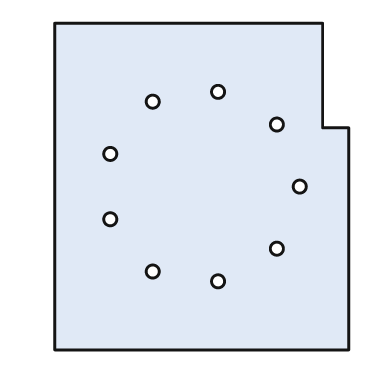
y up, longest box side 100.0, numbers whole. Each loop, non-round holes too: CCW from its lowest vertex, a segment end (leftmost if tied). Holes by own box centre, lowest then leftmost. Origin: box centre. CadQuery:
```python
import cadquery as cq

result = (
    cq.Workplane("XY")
    .moveTo(-45.0, -50.0)
    .lineTo(45.0, -50.0)
    .lineTo(45.0, 18.0)
    .lineTo(37.0, 18.0)
    .lineTo(37.0, 50.0)
    .lineTo(-45.0, 50.0)
    .close()
    .moveTo(5.0, -29.0)
    .circle(2.0)
    .moveTo(-15.0, -26.0)
    .circle(2.0)
    .moveTo(23.0, -19.0)
    .circle(2.0)
    .moveTo(-28.0, -10.0)
    .circle(2.0)
    .moveTo(30.0, 0.0)
    .circle(2.0)
    .moveTo(-28.0, 10.0)
    .circle(2.0)
    .moveTo(23.0, 19.0)
    .circle(2.0)
    .moveTo(-15.0, 26.0)
    .circle(2.0)
    .moveTo(5.0, 29.0)
    .circle(2.0)
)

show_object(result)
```